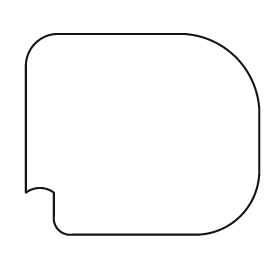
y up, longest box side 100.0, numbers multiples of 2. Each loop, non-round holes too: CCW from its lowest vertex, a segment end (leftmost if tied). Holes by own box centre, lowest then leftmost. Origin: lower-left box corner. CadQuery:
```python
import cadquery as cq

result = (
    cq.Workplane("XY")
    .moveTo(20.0, 0.0)
    .lineTo(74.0, 0.0)
    .threePointArc((92.0, 8.0), (100.0, 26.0))
    .lineTo(100.0, 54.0)
    .threePointArc((90.0, 76.0), (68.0, 86.0))
    .lineTo(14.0, 86.0)
    .threePointArc((4.0, 82.0), (0.0, 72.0))
    .lineTo(0.0, 18.0)
    .threePointArc((6.0, 20.0), (12.0, 18.0))
    .lineTo(12.0, 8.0)
    .threePointArc((14.0, 2.0), (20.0, 0.0))
    .close()
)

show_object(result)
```